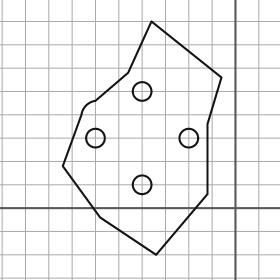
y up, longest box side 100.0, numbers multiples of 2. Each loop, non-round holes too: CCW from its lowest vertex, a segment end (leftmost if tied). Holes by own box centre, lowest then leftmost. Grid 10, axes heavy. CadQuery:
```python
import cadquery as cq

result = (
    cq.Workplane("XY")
    .moveTo(-34.0, -20.0)
    .lineTo(-12.0, 6.0)
    .lineTo(-12.0, 36.0)
    .lineTo(-6.0, 56.0)
    .lineTo(-36.0, 80.0)
    .lineTo(-46.0, 58.0)
    .lineTo(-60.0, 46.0)
    .threePointArc((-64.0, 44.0), (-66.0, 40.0))
    .lineTo(-74.0, 18.0)
    .lineTo(-58.0, -4.0)
    .close()
    .moveTo(-40.0, 10.0)
    .circle(4.0)
    .moveTo(-60.0, 30.0)
    .circle(4.0)
    .moveTo(-20.0, 30.0)
    .circle(4.0)
    .moveTo(-40.0, 50.0)
    .circle(4.0)
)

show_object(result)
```